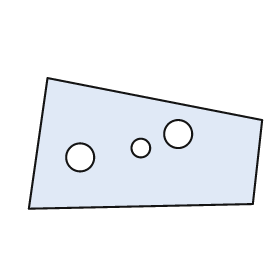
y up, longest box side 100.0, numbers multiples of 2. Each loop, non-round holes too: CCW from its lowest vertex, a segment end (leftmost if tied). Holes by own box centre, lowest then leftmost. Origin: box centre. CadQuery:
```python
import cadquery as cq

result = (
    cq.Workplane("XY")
    .moveTo(-50.0, -28.0)
    .lineTo(46.0, -26.0)
    .lineTo(50.0, 10.0)
    .lineTo(-42.0, 28.0)
    .close()
    .moveTo(-28.0, -6.0)
    .circle(6.0)
    .moveTo(-2.0, -2.0)
    .circle(4.0)
    .moveTo(14.0, 4.0)
    .circle(6.0)
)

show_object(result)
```